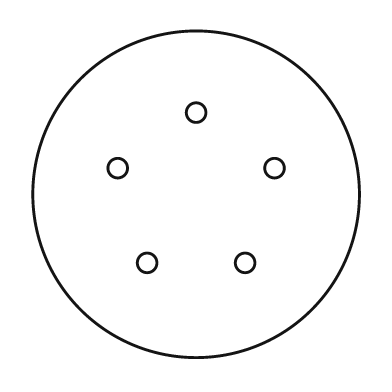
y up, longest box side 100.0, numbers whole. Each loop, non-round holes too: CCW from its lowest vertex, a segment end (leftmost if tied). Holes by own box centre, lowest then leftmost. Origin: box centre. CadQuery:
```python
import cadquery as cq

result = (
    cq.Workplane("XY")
    .moveTo(0.0, 0.0)
    .circle(50.0)
    .moveTo(-15.0, -21.0)
    .circle(3.0)
    .moveTo(15.0, -21.0)
    .circle(3.0)
    .moveTo(-24.0, 8.0)
    .circle(3.0)
    .moveTo(24.0, 8.0)
    .circle(3.0)
    .moveTo(0.0, 25.0)
    .circle(3.0)
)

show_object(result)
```